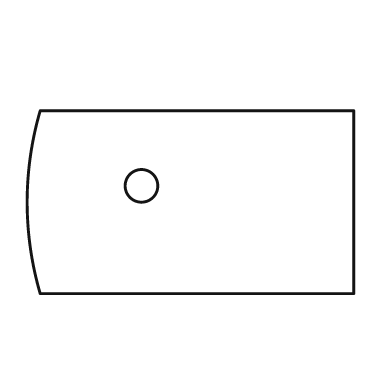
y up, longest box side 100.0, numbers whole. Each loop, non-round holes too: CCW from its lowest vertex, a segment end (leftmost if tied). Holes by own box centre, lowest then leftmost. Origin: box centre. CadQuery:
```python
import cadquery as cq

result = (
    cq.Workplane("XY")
    .moveTo(-46.0, -28.0)
    .lineTo(50.0, -28.0)
    .lineTo(50.0, 28.0)
    .lineTo(-46.0, 28.0)
    .threePointArc((-50.0, 0.0), (-46.0, -28.0))
    .close()
    .moveTo(-15.0, 5.0)
    .circle(5.0)
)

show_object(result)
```